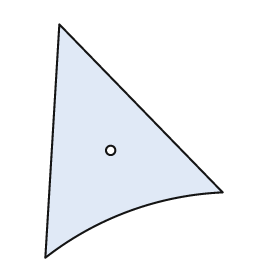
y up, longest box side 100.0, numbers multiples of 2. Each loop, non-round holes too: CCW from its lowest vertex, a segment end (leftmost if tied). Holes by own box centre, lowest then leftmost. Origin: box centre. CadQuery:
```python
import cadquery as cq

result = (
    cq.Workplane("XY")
    .moveTo(-38.0, -50.0)
    .threePointArc((-2.0, -30.0), (38.0, -22.0))
    .lineTo(-32.0, 50.0)
    .close()
    .moveTo(-10.0, -4.0)
    .circle(2.0)
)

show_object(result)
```